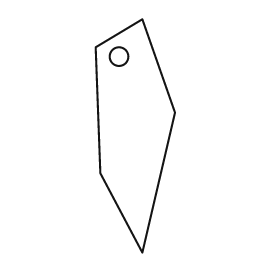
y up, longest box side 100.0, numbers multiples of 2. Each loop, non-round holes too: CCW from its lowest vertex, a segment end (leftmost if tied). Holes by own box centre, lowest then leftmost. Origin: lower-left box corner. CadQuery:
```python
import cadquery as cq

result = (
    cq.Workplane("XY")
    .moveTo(20.0, 0.0)
    .lineTo(34.0, 60.0)
    .lineTo(20.0, 100.0)
    .lineTo(0.0, 88.0)
    .lineTo(2.0, 34.0)
    .close()
    .moveTo(10.0, 84.0)
    .circle(4.0)
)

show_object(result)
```